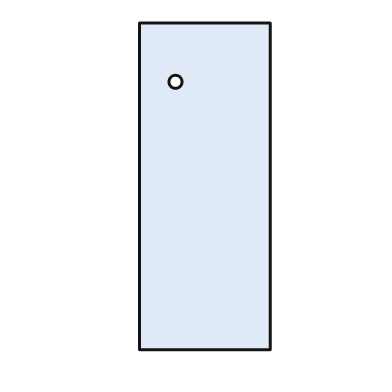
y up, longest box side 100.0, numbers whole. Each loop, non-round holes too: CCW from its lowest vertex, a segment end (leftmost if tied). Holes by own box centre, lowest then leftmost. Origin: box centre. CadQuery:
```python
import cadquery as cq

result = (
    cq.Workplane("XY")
    .moveTo(-20.0, -50.0)
    .lineTo(20.0, -50.0)
    .lineTo(20.0, 50.0)
    .lineTo(-20.0, 50.0)
    .close()
    .moveTo(-9.0, 32.0)
    .circle(2.0)
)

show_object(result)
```